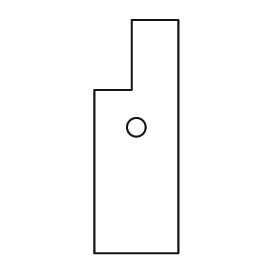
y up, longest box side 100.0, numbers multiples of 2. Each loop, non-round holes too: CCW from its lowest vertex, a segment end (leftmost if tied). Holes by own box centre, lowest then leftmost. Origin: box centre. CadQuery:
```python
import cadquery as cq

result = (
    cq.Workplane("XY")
    .moveTo(-18.0, -50.0)
    .lineTo(18.0, -50.0)
    .lineTo(18.0, 50.0)
    .lineTo(-2.0, 50.0)
    .lineTo(-2.0, 20.0)
    .lineTo(-18.0, 20.0)
    .close()
    .moveTo(0.0, 4.0)
    .circle(4.0)
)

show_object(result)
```